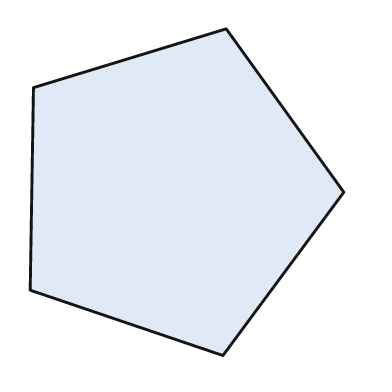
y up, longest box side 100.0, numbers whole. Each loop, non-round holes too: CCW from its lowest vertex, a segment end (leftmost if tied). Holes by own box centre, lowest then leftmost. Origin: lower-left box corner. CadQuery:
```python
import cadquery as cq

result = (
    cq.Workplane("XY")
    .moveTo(59.0, 0.0)
    .lineTo(96.0, 50.0)
    .lineTo(60.0, 100.0)
    .lineTo(1.0, 82.0)
    .lineTo(0.0, 20.0)
    .close()
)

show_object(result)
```